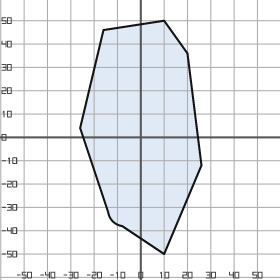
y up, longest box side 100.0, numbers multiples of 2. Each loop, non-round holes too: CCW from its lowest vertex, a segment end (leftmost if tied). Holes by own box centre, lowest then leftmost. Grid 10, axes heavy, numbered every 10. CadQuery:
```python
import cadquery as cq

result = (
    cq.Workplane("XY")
    .moveTo(10.0, -50.0)
    .lineTo(26.0, -12.0)
    .lineTo(20.0, 36.0)
    .lineTo(10.0, 50.0)
    .lineTo(-16.0, 46.0)
    .lineTo(-26.0, 4.0)
    .lineTo(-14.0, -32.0)
    .threePointArc((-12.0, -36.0), (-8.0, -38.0))
    .close()
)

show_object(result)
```